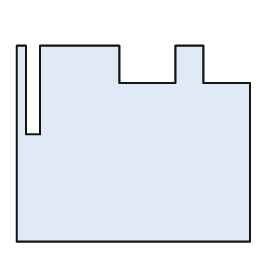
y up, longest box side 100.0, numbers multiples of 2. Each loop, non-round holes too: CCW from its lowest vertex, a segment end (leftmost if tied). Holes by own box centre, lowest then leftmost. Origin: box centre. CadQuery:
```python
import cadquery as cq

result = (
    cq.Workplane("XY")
    .moveTo(-50.0, -42.0)
    .lineTo(50.0, -42.0)
    .lineTo(50.0, 26.0)
    .lineTo(30.0, 26.0)
    .lineTo(30.0, 42.0)
    .lineTo(18.0, 42.0)
    .lineTo(18.0, 26.0)
    .lineTo(-6.0, 26.0)
    .lineTo(-6.0, 42.0)
    .lineTo(-40.0, 42.0)
    .lineTo(-40.0, 4.0)
    .lineTo(-46.0, 4.0)
    .lineTo(-46.0, 42.0)
    .lineTo(-50.0, 42.0)
    .close()
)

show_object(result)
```